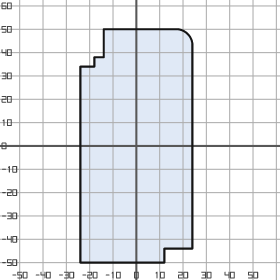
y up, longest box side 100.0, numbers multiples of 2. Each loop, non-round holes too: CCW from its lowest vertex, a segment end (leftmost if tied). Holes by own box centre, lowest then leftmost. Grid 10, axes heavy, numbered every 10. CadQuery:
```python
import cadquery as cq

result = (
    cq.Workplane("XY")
    .moveTo(-24.0, -50.0)
    .lineTo(12.0, -50.0)
    .lineTo(12.0, -44.0)
    .lineTo(24.0, -44.0)
    .lineTo(24.0, 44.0)
    .threePointArc((22.0, 48.0), (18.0, 50.0))
    .lineTo(-14.0, 50.0)
    .lineTo(-14.0, 38.0)
    .lineTo(-18.0, 38.0)
    .lineTo(-18.0, 34.0)
    .lineTo(-24.0, 34.0)
    .close()
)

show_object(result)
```